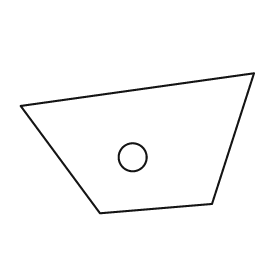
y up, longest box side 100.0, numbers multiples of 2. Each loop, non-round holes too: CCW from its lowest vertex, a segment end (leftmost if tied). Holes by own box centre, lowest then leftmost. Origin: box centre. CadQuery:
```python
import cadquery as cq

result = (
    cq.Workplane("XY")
    .moveTo(-16.0, -30.0)
    .lineTo(32.0, -26.0)
    .lineTo(50.0, 30.0)
    .lineTo(-50.0, 16.0)
    .close()
    .moveTo(-2.0, -6.0)
    .circle(6.0)
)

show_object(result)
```